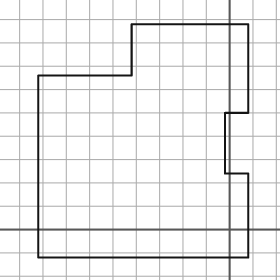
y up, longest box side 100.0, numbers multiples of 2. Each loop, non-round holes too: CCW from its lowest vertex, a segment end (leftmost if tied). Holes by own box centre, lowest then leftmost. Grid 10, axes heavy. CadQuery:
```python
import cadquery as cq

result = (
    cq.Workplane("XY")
    .moveTo(-82.0, -12.0)
    .lineTo(8.0, -12.0)
    .lineTo(8.0, 24.0)
    .lineTo(-2.0, 24.0)
    .lineTo(-2.0, 50.0)
    .lineTo(8.0, 50.0)
    .lineTo(8.0, 88.0)
    .lineTo(-42.0, 88.0)
    .lineTo(-42.0, 66.0)
    .lineTo(-82.0, 66.0)
    .close()
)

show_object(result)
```